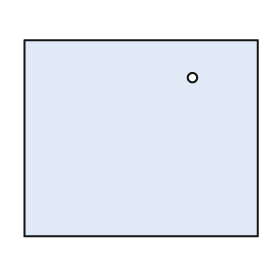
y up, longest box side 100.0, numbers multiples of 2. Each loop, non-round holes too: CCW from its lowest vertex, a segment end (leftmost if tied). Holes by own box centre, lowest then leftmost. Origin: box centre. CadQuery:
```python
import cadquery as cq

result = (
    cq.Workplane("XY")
    .moveTo(-50.0, -42.0)
    .lineTo(50.0, -42.0)
    .lineTo(50.0, 42.0)
    .lineTo(-50.0, 42.0)
    .close()
    .moveTo(22.0, 26.0)
    .circle(2.0)
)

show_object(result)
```